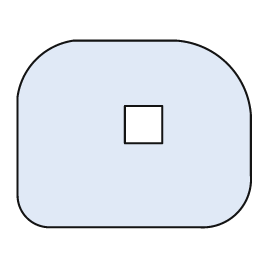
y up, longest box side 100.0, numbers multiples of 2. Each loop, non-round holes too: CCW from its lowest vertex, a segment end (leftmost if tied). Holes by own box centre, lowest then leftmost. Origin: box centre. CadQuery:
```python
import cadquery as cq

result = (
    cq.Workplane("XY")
    .moveTo(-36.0, -40.0)
    .lineTo(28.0, -40.0)
    .threePointArc((44.0, -34.0), (50.0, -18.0))
    .lineTo(50.0, 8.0)
    .threePointArc((40.0, 30.0), (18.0, 40.0))
    .lineTo(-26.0, 40.0)
    .threePointArc((-42.0, 32.0), (-50.0, 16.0))
    .lineTo(-50.0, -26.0)
    .threePointArc((-46.0, -36.0), (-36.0, -40.0))
    .close()
    .moveTo(-4.0, -4.0)
    .lineTo(12.0, -4.0)
    .lineTo(12.0, 12.0)
    .lineTo(-4.0, 12.0)
    .close()
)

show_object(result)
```